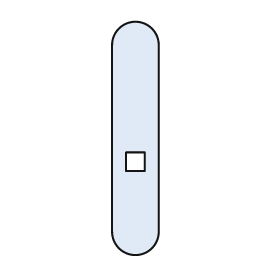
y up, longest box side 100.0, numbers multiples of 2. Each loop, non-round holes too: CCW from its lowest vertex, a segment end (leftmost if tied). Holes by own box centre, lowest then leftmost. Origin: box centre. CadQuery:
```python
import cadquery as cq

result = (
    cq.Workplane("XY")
    .moveTo(-10.0, -40.0)
    .threePointArc((0.0, -50.0), (10.0, -40.0))
    .lineTo(10.0, 40.0)
    .threePointArc((0.0, 50.0), (-10.0, 40.0))
    .close()
    .moveTo(-4.0, -14.0)
    .lineTo(4.0, -14.0)
    .lineTo(4.0, -6.0)
    .lineTo(-4.0, -6.0)
    .close()
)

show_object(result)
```